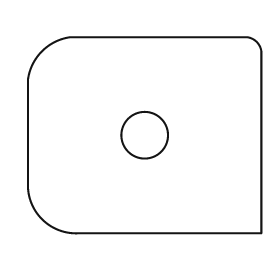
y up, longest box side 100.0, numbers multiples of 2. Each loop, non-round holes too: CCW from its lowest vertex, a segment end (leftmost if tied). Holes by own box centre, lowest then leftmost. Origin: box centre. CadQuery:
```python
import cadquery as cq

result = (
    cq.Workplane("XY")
    .moveTo(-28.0, -42.0)
    .lineTo(50.0, -42.0)
    .lineTo(50.0, 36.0)
    .threePointArc((48.0, 40.0), (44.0, 42.0))
    .lineTo(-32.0, 42.0)
    .threePointArc((-44.0, 36.0), (-50.0, 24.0))
    .lineTo(-50.0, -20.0)
    .threePointArc((-44.0, -36.0), (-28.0, -42.0))
    .close()
    .moveTo(0.0, 0.0)
    .circle(10.0)
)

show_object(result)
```